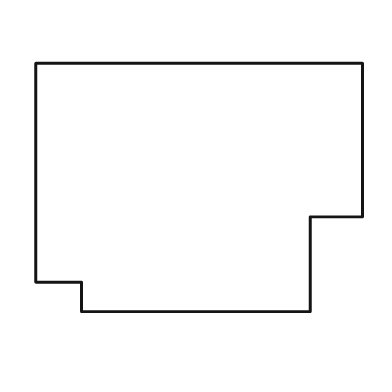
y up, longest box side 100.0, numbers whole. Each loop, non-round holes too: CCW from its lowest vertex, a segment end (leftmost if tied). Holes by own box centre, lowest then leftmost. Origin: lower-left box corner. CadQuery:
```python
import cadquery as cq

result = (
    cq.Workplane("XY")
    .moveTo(14.0, 0.0)
    .lineTo(84.0, 0.0)
    .lineTo(84.0, 29.0)
    .lineTo(100.0, 29.0)
    .lineTo(100.0, 76.0)
    .lineTo(0.0, 76.0)
    .lineTo(0.0, 9.0)
    .lineTo(14.0, 9.0)
    .close()
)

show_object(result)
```